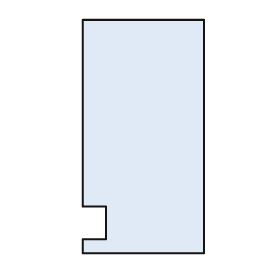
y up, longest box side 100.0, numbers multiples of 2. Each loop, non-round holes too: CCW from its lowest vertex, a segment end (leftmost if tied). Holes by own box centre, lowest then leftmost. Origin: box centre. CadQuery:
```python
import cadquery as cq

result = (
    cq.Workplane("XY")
    .moveTo(-26.0, -50.0)
    .lineTo(26.0, -50.0)
    .lineTo(26.0, 50.0)
    .lineTo(-26.0, 50.0)
    .lineTo(-26.0, -30.0)
    .lineTo(-16.0, -30.0)
    .lineTo(-16.0, -44.0)
    .lineTo(-26.0, -44.0)
    .close()
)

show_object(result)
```